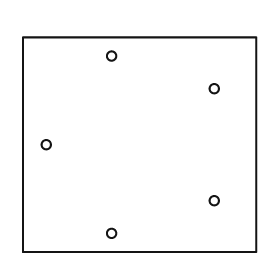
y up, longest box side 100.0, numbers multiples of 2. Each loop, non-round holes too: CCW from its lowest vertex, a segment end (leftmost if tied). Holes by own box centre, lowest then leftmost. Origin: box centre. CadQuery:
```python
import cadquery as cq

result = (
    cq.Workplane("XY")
    .moveTo(-50.0, -46.0)
    .lineTo(50.0, -46.0)
    .lineTo(50.0, 46.0)
    .lineTo(-50.0, 46.0)
    .close()
    .moveTo(-12.0, -38.0)
    .circle(2.0)
    .moveTo(32.0, -24.0)
    .circle(2.0)
    .moveTo(-40.0, 0.0)
    .circle(2.0)
    .moveTo(32.0, 24.0)
    .circle(2.0)
    .moveTo(-12.0, 38.0)
    .circle(2.0)
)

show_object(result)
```